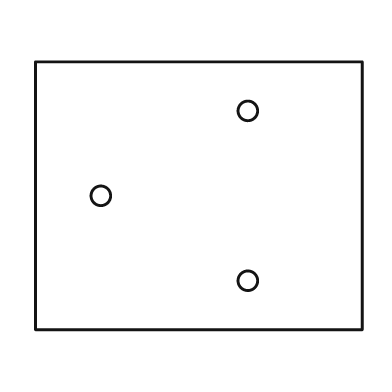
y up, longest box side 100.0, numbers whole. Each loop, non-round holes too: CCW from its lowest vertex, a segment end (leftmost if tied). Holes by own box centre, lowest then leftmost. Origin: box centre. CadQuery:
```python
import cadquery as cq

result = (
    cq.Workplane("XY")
    .moveTo(-50.0, -41.0)
    .lineTo(50.0, -41.0)
    .lineTo(50.0, 41.0)
    .lineTo(-50.0, 41.0)
    .close()
    .moveTo(15.0, -26.0)
    .circle(3.0)
    .moveTo(-30.0, 0.0)
    .circle(3.0)
    .moveTo(15.0, 26.0)
    .circle(3.0)
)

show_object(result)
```